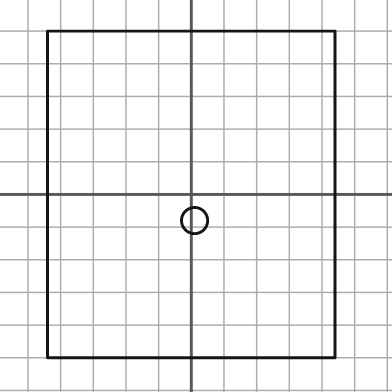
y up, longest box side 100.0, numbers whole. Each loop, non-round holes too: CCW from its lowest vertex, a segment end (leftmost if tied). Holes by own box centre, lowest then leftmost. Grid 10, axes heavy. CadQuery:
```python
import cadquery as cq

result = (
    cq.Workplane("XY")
    .moveTo(-44.0, -50.0)
    .lineTo(44.0, -50.0)
    .lineTo(44.0, 50.0)
    .lineTo(-44.0, 50.0)
    .close()
    .moveTo(1.0, -8.0)
    .circle(4.0)
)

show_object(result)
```